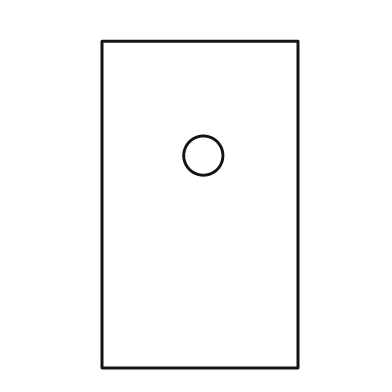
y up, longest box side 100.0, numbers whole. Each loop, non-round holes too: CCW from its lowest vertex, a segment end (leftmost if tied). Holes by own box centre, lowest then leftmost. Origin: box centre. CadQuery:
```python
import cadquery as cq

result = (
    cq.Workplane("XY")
    .moveTo(-30.0, -50.0)
    .lineTo(30.0, -50.0)
    .lineTo(30.0, 50.0)
    .lineTo(-30.0, 50.0)
    .close()
    .moveTo(1.0, 15.0)
    .circle(6.0)
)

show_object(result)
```